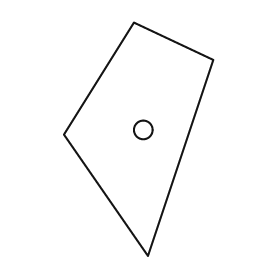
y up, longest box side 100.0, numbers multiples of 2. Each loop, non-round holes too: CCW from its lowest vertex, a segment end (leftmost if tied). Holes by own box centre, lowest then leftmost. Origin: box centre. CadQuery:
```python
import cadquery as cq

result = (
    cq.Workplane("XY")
    .moveTo(4.0, -50.0)
    .lineTo(32.0, 34.0)
    .lineTo(-2.0, 50.0)
    .lineTo(-32.0, 2.0)
    .close()
    .moveTo(2.0, 4.0)
    .circle(4.0)
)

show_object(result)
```